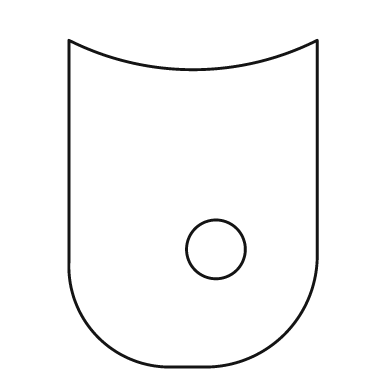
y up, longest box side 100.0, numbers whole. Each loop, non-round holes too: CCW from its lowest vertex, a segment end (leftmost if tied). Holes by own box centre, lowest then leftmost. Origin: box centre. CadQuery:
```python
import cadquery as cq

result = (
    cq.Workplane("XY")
    .moveTo(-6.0, -50.0)
    .lineTo(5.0, -50.0)
    .threePointArc((28.0, -40.0), (38.0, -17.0))
    .lineTo(38.0, 50.0)
    .threePointArc((0.0, 41.0), (-38.0, 50.0))
    .lineTo(-38.0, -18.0)
    .threePointArc((-29.0, -41.0), (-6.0, -50.0))
    .close()
    .moveTo(7.0, -14.0)
    .circle(9.0)
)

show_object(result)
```